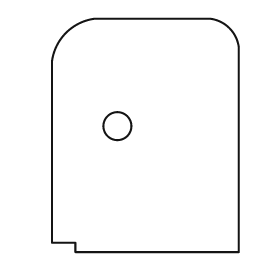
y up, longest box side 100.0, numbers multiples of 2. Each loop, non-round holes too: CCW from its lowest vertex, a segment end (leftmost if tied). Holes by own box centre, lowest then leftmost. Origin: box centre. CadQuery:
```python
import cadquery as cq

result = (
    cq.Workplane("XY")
    .moveTo(-30.0, -50.0)
    .lineTo(40.0, -50.0)
    .lineTo(40.0, 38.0)
    .threePointArc((36.0, 46.0), (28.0, 50.0))
    .lineTo(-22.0, 50.0)
    .threePointArc((-34.0, 44.0), (-40.0, 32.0))
    .lineTo(-40.0, -46.0)
    .lineTo(-30.0, -46.0)
    .close()
    .moveTo(-12.0, 4.0)
    .circle(6.0)
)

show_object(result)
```